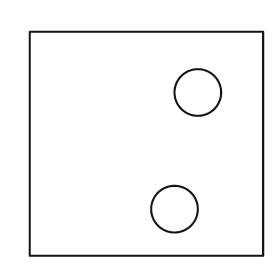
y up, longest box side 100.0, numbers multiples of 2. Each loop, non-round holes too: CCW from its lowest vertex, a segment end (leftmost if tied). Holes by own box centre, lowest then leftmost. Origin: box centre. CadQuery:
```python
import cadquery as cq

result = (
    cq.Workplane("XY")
    .moveTo(-50.0, -48.0)
    .lineTo(50.0, -48.0)
    .lineTo(50.0, 48.0)
    .lineTo(-50.0, 48.0)
    .close()
    .moveTo(12.0, -28.0)
    .circle(10.0)
    .moveTo(22.0, 22.0)
    .circle(10.0)
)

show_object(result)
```